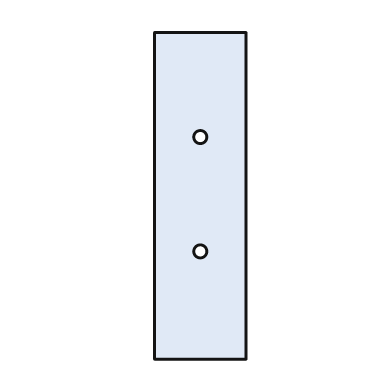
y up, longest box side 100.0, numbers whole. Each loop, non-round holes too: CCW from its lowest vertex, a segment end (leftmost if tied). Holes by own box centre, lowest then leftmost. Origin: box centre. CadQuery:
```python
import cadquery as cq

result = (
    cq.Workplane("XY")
    .moveTo(-14.0, -50.0)
    .lineTo(14.0, -50.0)
    .lineTo(14.0, 50.0)
    .lineTo(-14.0, 50.0)
    .close()
    .moveTo(0.0, -17.0)
    .circle(2.0)
    .moveTo(0.0, 18.0)
    .circle(2.0)
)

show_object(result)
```